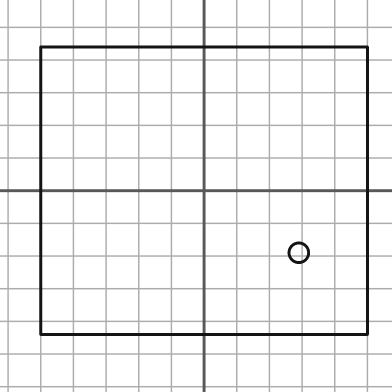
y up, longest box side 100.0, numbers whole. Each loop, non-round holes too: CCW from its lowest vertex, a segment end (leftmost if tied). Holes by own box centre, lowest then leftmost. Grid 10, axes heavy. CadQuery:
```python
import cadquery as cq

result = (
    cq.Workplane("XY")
    .moveTo(-50.0, -44.0)
    .lineTo(50.0, -44.0)
    .lineTo(50.0, 44.0)
    .lineTo(-50.0, 44.0)
    .close()
    .moveTo(29.0, -19.0)
    .circle(3.0)
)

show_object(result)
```